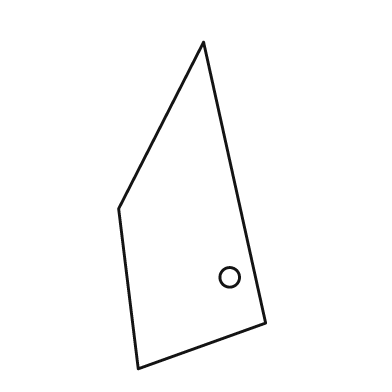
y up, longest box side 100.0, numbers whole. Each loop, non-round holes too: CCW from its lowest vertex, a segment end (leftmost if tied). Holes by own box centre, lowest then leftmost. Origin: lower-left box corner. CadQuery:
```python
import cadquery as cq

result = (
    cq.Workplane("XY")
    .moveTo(6.0, 0.0)
    .lineTo(45.0, 14.0)
    .lineTo(26.0, 100.0)
    .lineTo(0.0, 49.0)
    .close()
    .moveTo(34.0, 28.0)
    .circle(3.0)
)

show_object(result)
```